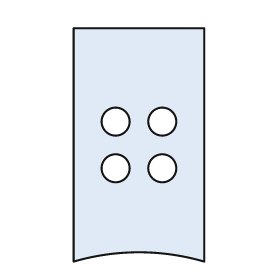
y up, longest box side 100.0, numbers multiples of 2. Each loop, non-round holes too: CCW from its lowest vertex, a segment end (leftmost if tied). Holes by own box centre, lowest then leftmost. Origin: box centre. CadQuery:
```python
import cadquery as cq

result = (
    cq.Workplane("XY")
    .moveTo(-28.0, -50.0)
    .threePointArc((0.0, -46.0), (28.0, -50.0))
    .lineTo(28.0, 50.0)
    .lineTo(-28.0, 50.0)
    .close()
    .moveTo(-10.0, -10.0)
    .circle(6.0)
    .moveTo(10.0, -10.0)
    .circle(6.0)
    .moveTo(-10.0, 10.0)
    .circle(6.0)
    .moveTo(10.0, 10.0)
    .circle(6.0)
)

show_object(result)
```